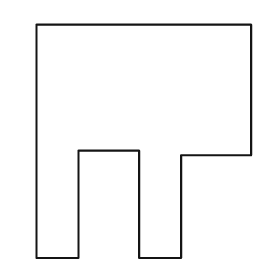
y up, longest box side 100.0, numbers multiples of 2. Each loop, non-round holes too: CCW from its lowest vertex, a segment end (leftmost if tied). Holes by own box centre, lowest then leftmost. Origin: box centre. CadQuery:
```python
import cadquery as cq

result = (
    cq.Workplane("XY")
    .moveTo(-46.0, -50.0)
    .lineTo(-28.0, -50.0)
    .lineTo(-28.0, -4.0)
    .lineTo(-2.0, -4.0)
    .lineTo(-2.0, -50.0)
    .lineTo(16.0, -50.0)
    .lineTo(16.0, -6.0)
    .lineTo(46.0, -6.0)
    .lineTo(46.0, 50.0)
    .lineTo(-46.0, 50.0)
    .close()
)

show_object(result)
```